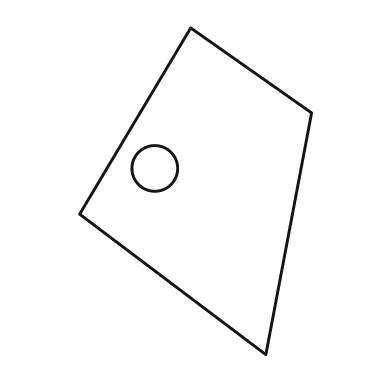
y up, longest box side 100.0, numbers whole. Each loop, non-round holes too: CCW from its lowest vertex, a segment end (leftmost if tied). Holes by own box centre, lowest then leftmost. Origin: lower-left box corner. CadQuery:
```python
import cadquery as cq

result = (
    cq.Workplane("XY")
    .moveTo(57.0, 0.0)
    .lineTo(71.0, 74.0)
    .lineTo(34.0, 100.0)
    .lineTo(0.0, 43.0)
    .close()
    .moveTo(23.0, 57.0)
    .circle(7.0)
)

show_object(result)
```